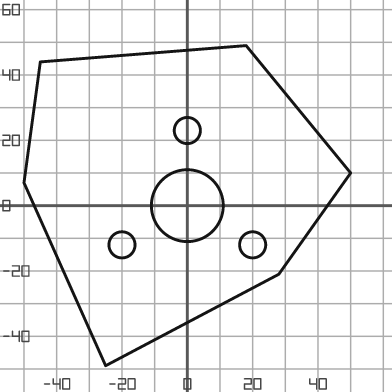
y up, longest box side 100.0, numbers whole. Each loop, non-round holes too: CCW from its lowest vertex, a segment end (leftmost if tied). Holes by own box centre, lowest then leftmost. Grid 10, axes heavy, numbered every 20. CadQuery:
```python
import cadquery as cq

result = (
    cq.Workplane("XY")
    .moveTo(-25.0, -49.0)
    .lineTo(28.0, -21.0)
    .lineTo(50.0, 10.0)
    .lineTo(18.0, 49.0)
    .lineTo(-45.0, 44.0)
    .lineTo(-50.0, 7.0)
    .close()
    .moveTo(-20.0, -12.0)
    .circle(4.0)
    .moveTo(20.0, -12.0)
    .circle(4.0)
    .moveTo(0.0, 0.0)
    .circle(11.0)
    .moveTo(0.0, 23.0)
    .circle(4.0)
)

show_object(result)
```